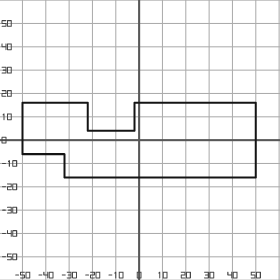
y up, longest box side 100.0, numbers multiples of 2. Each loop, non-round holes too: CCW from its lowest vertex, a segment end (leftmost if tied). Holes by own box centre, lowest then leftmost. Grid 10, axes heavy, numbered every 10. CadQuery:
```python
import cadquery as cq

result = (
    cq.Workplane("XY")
    .moveTo(-32.0, -16.0)
    .lineTo(50.0, -16.0)
    .lineTo(50.0, 16.0)
    .lineTo(-2.0, 16.0)
    .lineTo(-2.0, 4.0)
    .lineTo(-22.0, 4.0)
    .lineTo(-22.0, 16.0)
    .lineTo(-50.0, 16.0)
    .lineTo(-50.0, -6.0)
    .lineTo(-32.0, -6.0)
    .close()
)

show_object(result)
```